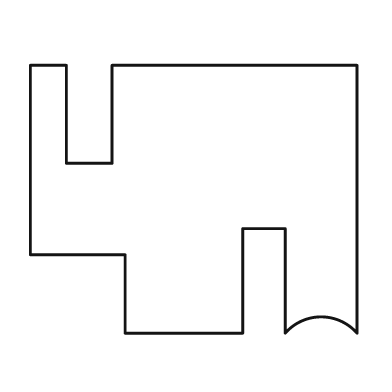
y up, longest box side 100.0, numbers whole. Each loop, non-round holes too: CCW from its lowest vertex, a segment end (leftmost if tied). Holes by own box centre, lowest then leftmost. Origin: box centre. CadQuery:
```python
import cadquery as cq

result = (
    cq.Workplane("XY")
    .moveTo(-21.0, -41.0)
    .lineTo(15.0, -41.0)
    .lineTo(15.0, -9.0)
    .lineTo(28.0, -9.0)
    .lineTo(28.0, -41.0)
    .threePointArc((39.0, -36.0), (50.0, -41.0))
    .lineTo(50.0, 41.0)
    .lineTo(-25.0, 41.0)
    .lineTo(-25.0, 11.0)
    .lineTo(-39.0, 11.0)
    .lineTo(-39.0, 41.0)
    .lineTo(-50.0, 41.0)
    .lineTo(-50.0, -17.0)
    .lineTo(-21.0, -17.0)
    .close()
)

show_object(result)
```